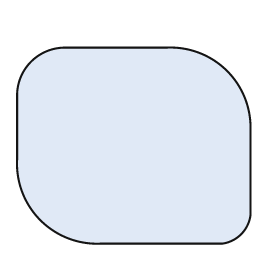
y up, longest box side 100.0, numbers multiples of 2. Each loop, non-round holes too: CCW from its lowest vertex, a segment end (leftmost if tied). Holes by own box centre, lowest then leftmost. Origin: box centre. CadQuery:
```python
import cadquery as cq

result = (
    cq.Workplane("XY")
    .moveTo(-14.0, -42.0)
    .lineTo(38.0, -42.0)
    .threePointArc((46.0, -38.0), (50.0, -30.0))
    .lineTo(50.0, 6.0)
    .threePointArc((40.0, 32.0), (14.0, 42.0))
    .lineTo(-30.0, 42.0)
    .threePointArc((-44.0, 36.0), (-50.0, 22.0))
    .lineTo(-50.0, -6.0)
    .threePointArc((-40.0, -32.0), (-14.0, -42.0))
    .close()
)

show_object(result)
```